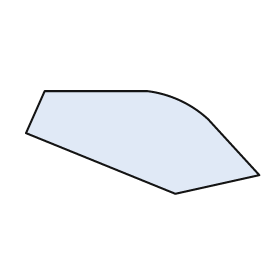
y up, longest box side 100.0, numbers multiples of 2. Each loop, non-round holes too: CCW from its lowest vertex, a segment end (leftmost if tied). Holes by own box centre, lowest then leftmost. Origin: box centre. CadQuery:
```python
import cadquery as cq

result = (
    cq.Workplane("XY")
    .moveTo(14.0, -22.0)
    .lineTo(50.0, -14.0)
    .lineTo(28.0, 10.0)
    .threePointArc((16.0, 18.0), (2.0, 22.0))
    .lineTo(-42.0, 22.0)
    .lineTo(-50.0, 4.0)
    .close()
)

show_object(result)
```